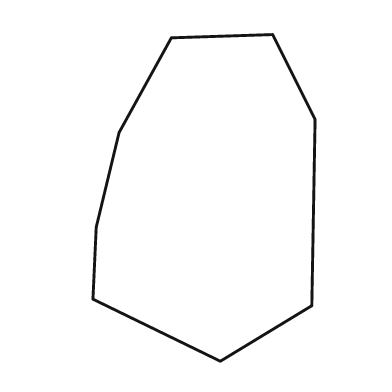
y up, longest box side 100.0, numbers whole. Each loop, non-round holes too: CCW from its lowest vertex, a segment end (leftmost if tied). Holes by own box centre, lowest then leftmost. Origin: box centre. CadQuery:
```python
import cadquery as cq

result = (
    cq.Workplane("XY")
    .moveTo(5.0, -50.0)
    .lineTo(33.0, -33.0)
    .lineTo(34.0, 24.0)
    .lineTo(21.0, 50.0)
    .lineTo(-10.0, 49.0)
    .lineTo(-26.0, 20.0)
    .lineTo(-33.0, -9.0)
    .lineTo(-34.0, -31.0)
    .close()
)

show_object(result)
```